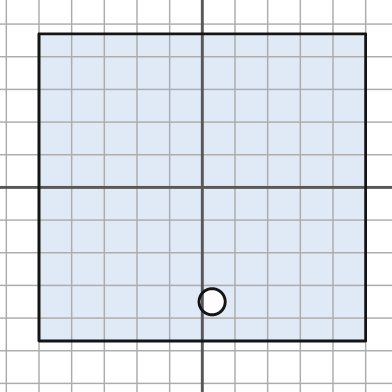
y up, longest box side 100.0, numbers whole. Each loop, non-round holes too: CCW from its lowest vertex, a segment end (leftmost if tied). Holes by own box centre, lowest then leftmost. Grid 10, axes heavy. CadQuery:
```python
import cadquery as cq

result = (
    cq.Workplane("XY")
    .moveTo(-50.0, -47.0)
    .lineTo(50.0, -47.0)
    .lineTo(50.0, 47.0)
    .lineTo(-50.0, 47.0)
    .close()
    .moveTo(3.0, -35.0)
    .circle(4.0)
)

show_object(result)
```